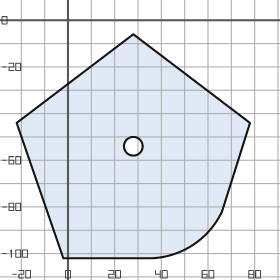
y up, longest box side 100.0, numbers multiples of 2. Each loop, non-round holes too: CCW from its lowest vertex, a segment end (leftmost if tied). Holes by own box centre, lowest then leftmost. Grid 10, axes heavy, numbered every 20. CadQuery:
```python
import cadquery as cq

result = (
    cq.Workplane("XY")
    .moveTo(-2.0, -102.0)
    .lineTo(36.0, -102.0)
    .threePointArc((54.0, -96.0), (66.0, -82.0))
    .lineTo(78.0, -44.0)
    .lineTo(28.0, -6.0)
    .lineTo(-22.0, -44.0)
    .close()
    .moveTo(28.0, -54.0)
    .circle(4.0)
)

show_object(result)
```